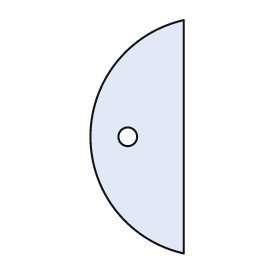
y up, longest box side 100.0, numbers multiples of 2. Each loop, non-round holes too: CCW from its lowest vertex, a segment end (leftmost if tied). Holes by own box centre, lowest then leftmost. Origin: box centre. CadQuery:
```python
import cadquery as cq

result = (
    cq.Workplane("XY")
    .moveTo(20.0, -50.0)
    .lineTo(20.0, 50.0)
    .threePointArc((-20.0, 0.0), (20.0, -50.0))
    .close()
    .moveTo(-4.0, 0.0)
    .circle(4.0)
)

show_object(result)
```